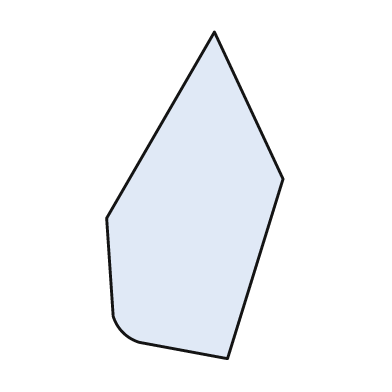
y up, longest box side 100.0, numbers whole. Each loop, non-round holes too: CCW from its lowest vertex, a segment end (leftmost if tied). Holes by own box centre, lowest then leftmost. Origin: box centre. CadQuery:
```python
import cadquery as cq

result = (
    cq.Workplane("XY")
    .moveTo(10.0, -50.0)
    .lineTo(27.0, 5.0)
    .lineTo(6.0, 50.0)
    .lineTo(-27.0, -7.0)
    .lineTo(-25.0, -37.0)
    .threePointArc((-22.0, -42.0), (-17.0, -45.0))
    .close()
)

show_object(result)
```